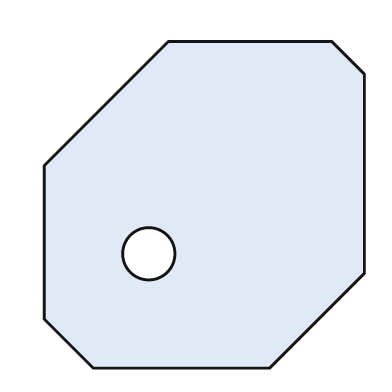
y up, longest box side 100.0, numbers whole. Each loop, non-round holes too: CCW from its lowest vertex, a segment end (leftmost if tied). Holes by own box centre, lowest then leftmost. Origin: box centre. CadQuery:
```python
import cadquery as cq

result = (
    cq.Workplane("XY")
    .moveTo(-34.0, -50.0)
    .lineTo(20.0, -50.0)
    .lineTo(49.0, -21.0)
    .lineTo(49.0, 40.0)
    .lineTo(39.0, 50.0)
    .lineTo(-11.0, 50.0)
    .lineTo(-49.0, 12.0)
    .lineTo(-49.0, -35.0)
    .close()
    .moveTo(-17.0, -15.0)
    .circle(8.0)
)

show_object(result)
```